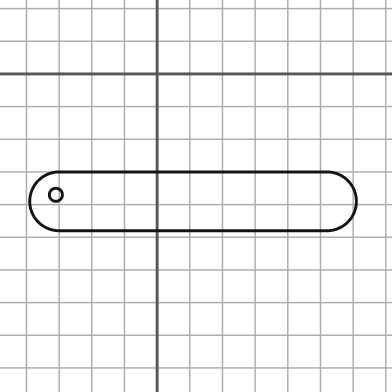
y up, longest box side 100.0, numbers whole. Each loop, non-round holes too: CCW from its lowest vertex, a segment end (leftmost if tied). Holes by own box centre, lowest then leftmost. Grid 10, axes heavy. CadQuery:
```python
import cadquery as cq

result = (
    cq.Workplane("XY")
    .moveTo(-30.0, -48.0)
    .lineTo(52.0, -48.0)
    .threePointArc((61.0, -39.0), (52.0, -30.0))
    .lineTo(-30.0, -30.0)
    .threePointArc((-39.0, -39.0), (-30.0, -48.0))
    .close()
    .moveTo(-31.0, -37.0)
    .circle(2.0)
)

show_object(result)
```